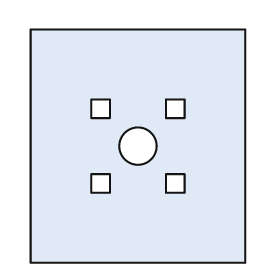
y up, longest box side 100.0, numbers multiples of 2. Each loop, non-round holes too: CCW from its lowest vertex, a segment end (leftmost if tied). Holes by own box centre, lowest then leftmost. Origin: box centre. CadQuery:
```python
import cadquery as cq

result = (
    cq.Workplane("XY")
    .moveTo(-46.0, -50.0)
    .lineTo(46.0, -50.0)
    .lineTo(46.0, 50.0)
    .lineTo(-46.0, 50.0)
    .close()
    .moveTo(-20.0, -20.0)
    .lineTo(-12.0, -20.0)
    .lineTo(-12.0, -12.0)
    .lineTo(-20.0, -12.0)
    .close()
    .moveTo(12.0, -20.0)
    .lineTo(20.0, -20.0)
    .lineTo(20.0, -12.0)
    .lineTo(12.0, -12.0)
    .close()
    .moveTo(0.0, 0.0)
    .circle(8.0)
    .moveTo(-20.0, 12.0)
    .lineTo(-12.0, 12.0)
    .lineTo(-12.0, 20.0)
    .lineTo(-20.0, 20.0)
    .close()
    .moveTo(12.0, 12.0)
    .lineTo(20.0, 12.0)
    .lineTo(20.0, 20.0)
    .lineTo(12.0, 20.0)
    .close()
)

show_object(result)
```